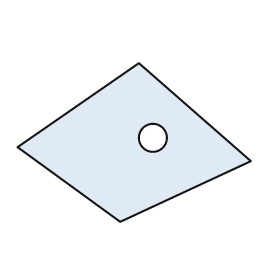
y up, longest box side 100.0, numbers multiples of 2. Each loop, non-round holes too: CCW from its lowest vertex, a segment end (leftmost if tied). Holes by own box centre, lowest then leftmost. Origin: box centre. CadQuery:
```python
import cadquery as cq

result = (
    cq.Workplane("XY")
    .moveTo(-6.0, -34.0)
    .lineTo(50.0, -8.0)
    .lineTo(2.0, 34.0)
    .lineTo(-50.0, -2.0)
    .close()
    .moveTo(8.0, 2.0)
    .circle(6.0)
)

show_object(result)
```